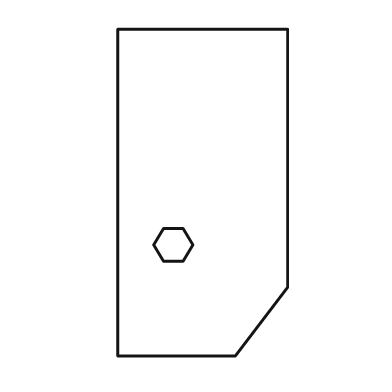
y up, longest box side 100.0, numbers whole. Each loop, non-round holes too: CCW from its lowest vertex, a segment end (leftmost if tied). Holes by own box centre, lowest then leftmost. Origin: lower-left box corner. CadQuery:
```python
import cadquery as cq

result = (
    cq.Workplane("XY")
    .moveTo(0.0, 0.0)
    .lineTo(36.0, 0.0)
    .lineTo(52.0, 21.0)
    .lineTo(52.0, 100.0)
    .lineTo(0.0, 100.0)
    .close()
    .moveTo(14.0, 29.0)
    .lineTo(20.0, 29.0)
    .lineTo(23.0, 34.0)
    .lineTo(20.0, 39.0)
    .lineTo(14.0, 39.0)
    .lineTo(11.0, 34.0)
    .close()
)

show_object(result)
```